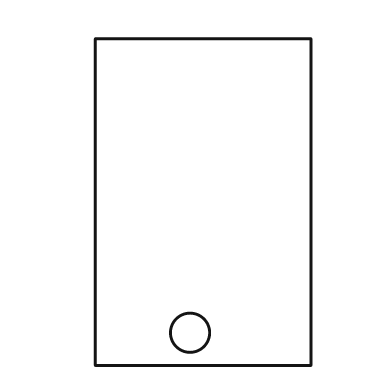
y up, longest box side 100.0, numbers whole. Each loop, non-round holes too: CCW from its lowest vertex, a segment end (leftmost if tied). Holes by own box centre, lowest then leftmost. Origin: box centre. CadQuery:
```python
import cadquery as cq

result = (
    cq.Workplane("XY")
    .moveTo(-33.0, -50.0)
    .lineTo(33.0, -50.0)
    .lineTo(33.0, 50.0)
    .lineTo(-33.0, 50.0)
    .close()
    .moveTo(-4.0, -40.0)
    .circle(6.0)
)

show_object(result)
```